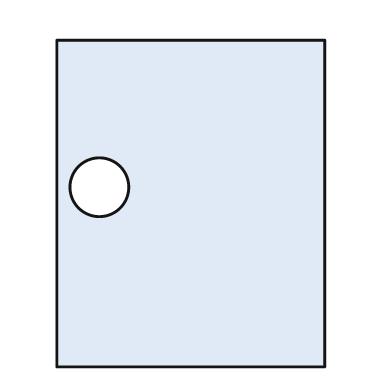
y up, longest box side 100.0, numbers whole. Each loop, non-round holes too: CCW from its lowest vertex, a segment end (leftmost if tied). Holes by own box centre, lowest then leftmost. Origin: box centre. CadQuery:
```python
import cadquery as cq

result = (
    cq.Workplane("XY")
    .moveTo(-41.0, -50.0)
    .lineTo(41.0, -50.0)
    .lineTo(41.0, 50.0)
    .lineTo(-41.0, 50.0)
    .close()
    .moveTo(-28.0, 5.0)
    .circle(9.0)
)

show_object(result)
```